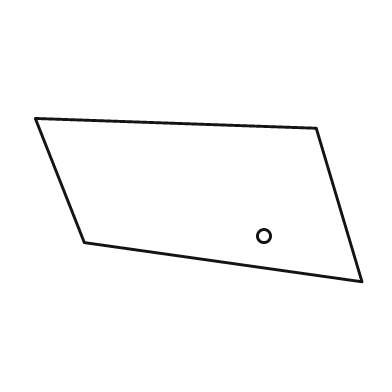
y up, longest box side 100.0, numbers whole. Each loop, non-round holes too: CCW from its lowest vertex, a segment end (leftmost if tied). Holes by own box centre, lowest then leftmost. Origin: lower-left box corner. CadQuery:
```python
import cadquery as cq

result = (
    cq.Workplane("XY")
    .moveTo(100.0, 0.0)
    .lineTo(86.0, 47.0)
    .lineTo(0.0, 50.0)
    .lineTo(15.0, 12.0)
    .close()
    .moveTo(70.0, 14.0)
    .circle(2.0)
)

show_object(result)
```